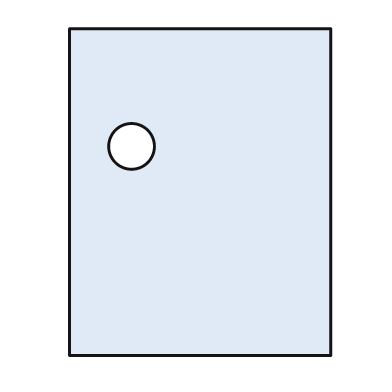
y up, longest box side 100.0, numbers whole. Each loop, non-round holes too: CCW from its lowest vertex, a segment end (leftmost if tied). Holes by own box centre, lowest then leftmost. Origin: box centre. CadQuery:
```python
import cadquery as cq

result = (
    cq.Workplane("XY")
    .moveTo(-40.0, -50.0)
    .lineTo(40.0, -50.0)
    .lineTo(40.0, 50.0)
    .lineTo(-40.0, 50.0)
    .close()
    .moveTo(-21.0, 14.0)
    .circle(7.0)
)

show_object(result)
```